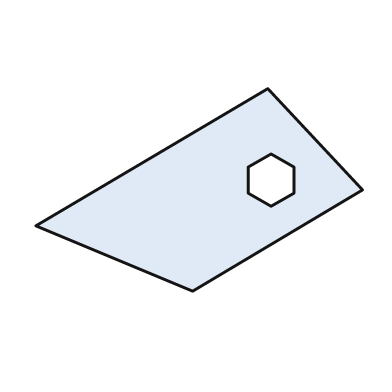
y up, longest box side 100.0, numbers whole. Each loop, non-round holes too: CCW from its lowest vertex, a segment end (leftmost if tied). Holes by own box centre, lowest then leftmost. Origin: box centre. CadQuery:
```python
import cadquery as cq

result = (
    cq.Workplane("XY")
    .moveTo(-2.0, -31.0)
    .lineTo(50.0, 0.0)
    .lineTo(21.0, 31.0)
    .lineTo(-50.0, -11.0)
    .close()
    .moveTo(22.0, -5.0)
    .lineTo(29.0, -1.0)
    .lineTo(29.0, 7.0)
    .lineTo(22.0, 11.0)
    .lineTo(15.0, 7.0)
    .lineTo(15.0, -1.0)
    .close()
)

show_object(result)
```